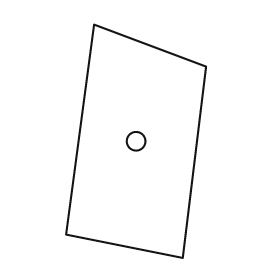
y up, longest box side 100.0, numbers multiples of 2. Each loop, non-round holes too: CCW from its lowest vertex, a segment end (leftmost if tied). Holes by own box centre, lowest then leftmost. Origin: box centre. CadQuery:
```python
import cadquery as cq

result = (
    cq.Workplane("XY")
    .moveTo(20.0, -50.0)
    .lineTo(30.0, 32.0)
    .lineTo(-18.0, 50.0)
    .lineTo(-30.0, -40.0)
    .close()
    .moveTo(0.0, 0.0)
    .circle(4.0)
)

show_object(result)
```